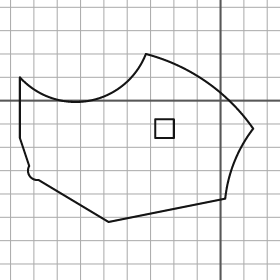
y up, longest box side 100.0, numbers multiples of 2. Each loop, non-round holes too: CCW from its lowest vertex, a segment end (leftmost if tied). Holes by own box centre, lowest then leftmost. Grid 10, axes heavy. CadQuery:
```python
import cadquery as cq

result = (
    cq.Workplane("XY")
    .moveTo(-48.0, -52.0)
    .lineTo(2.0, -42.0)
    .threePointArc((6.0, -26.0), (14.0, -12.0))
    .threePointArc((-6.0, 8.0), (-32.0, 20.0))
    .threePointArc((-56.0, 0.0), (-86.0, 10.0))
    .lineTo(-86.0, -16.0)
    .lineTo(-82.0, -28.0)
    .threePointArc((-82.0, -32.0), (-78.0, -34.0))
    .close()
    .moveTo(-28.0, -16.0)
    .lineTo(-20.0, -16.0)
    .lineTo(-20.0, -8.0)
    .lineTo(-28.0, -8.0)
    .close()
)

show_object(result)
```